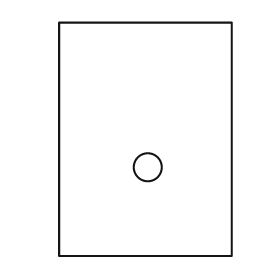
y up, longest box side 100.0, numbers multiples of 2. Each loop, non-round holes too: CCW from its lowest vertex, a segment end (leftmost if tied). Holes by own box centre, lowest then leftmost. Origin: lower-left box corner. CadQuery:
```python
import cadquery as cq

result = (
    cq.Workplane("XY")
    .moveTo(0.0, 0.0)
    .lineTo(74.0, 0.0)
    .lineTo(74.0, 100.0)
    .lineTo(0.0, 100.0)
    .close()
    .moveTo(38.0, 38.0)
    .circle(6.0)
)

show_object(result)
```